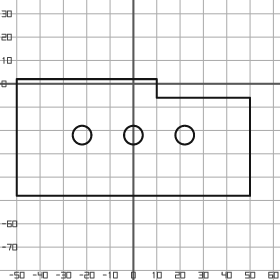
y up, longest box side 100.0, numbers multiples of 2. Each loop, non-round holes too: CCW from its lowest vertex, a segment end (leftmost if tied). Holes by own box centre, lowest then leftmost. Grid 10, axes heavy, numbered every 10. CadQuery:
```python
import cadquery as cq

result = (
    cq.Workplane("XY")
    .moveTo(-50.0, -48.0)
    .lineTo(50.0, -48.0)
    .lineTo(50.0, -6.0)
    .lineTo(10.0, -6.0)
    .lineTo(10.0, 2.0)
    .lineTo(-50.0, 2.0)
    .close()
    .moveTo(-22.0, -22.0)
    .circle(4.0)
    .moveTo(0.0, -22.0)
    .circle(4.0)
    .moveTo(22.0, -22.0)
    .circle(4.0)
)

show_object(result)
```